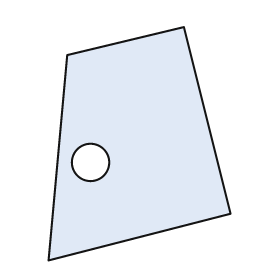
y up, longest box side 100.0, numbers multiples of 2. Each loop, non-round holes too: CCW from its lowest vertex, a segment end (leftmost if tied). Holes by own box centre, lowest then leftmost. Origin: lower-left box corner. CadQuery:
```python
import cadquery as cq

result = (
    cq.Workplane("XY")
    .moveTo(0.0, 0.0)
    .lineTo(78.0, 20.0)
    .lineTo(58.0, 100.0)
    .lineTo(8.0, 88.0)
    .close()
    .moveTo(18.0, 42.0)
    .circle(8.0)
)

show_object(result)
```